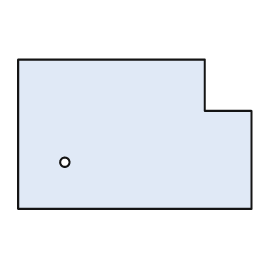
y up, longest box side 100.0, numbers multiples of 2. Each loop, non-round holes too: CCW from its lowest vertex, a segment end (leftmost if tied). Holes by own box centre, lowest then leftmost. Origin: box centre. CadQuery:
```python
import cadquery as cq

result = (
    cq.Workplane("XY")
    .moveTo(-50.0, -32.0)
    .lineTo(50.0, -32.0)
    .lineTo(50.0, 10.0)
    .lineTo(30.0, 10.0)
    .lineTo(30.0, 32.0)
    .lineTo(-50.0, 32.0)
    .close()
    .moveTo(-30.0, -12.0)
    .circle(2.0)
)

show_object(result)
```